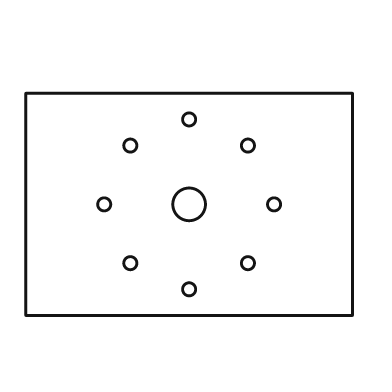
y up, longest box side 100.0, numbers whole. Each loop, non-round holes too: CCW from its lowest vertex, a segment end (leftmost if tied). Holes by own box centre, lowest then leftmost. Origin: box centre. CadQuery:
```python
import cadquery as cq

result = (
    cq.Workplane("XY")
    .moveTo(-50.0, -34.0)
    .lineTo(50.0, -34.0)
    .lineTo(50.0, 34.0)
    .lineTo(-50.0, 34.0)
    .close()
    .moveTo(0.0, -26.0)
    .circle(2.0)
    .moveTo(-18.0, -18.0)
    .circle(2.0)
    .moveTo(18.0, -18.0)
    .circle(2.0)
    .moveTo(-26.0, 0.0)
    .circle(2.0)
    .moveTo(0.0, 0.0)
    .circle(5.0)
    .moveTo(26.0, 0.0)
    .circle(2.0)
    .moveTo(-18.0, 18.0)
    .circle(2.0)
    .moveTo(18.0, 18.0)
    .circle(2.0)
    .moveTo(0.0, 26.0)
    .circle(2.0)
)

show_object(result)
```